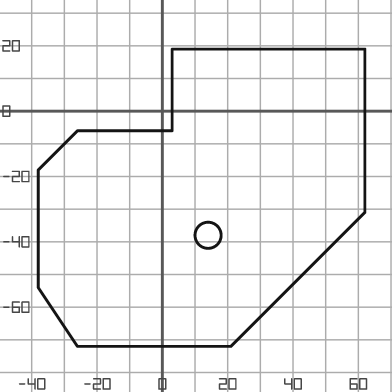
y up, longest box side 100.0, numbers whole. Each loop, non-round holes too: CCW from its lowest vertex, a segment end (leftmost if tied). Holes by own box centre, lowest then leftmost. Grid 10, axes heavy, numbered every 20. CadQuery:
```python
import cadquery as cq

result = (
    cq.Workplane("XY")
    .moveTo(-26.0, -72.0)
    .lineTo(21.0, -72.0)
    .lineTo(62.0, -31.0)
    .lineTo(62.0, 19.0)
    .lineTo(3.0, 19.0)
    .lineTo(3.0, -6.0)
    .lineTo(-26.0, -6.0)
    .lineTo(-38.0, -18.0)
    .lineTo(-38.0, -54.0)
    .close()
    .moveTo(14.0, -38.0)
    .circle(4.0)
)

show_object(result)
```